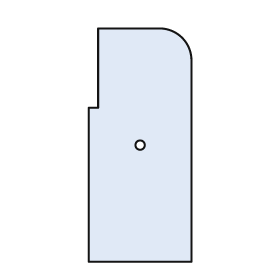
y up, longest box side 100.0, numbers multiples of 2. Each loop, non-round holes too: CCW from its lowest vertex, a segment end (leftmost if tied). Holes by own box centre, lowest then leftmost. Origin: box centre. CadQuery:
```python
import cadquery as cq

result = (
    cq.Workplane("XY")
    .moveTo(-22.0, -50.0)
    .lineTo(22.0, -50.0)
    .lineTo(22.0, 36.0)
    .threePointArc((18.0, 46.0), (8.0, 50.0))
    .lineTo(-18.0, 50.0)
    .lineTo(-18.0, 16.0)
    .lineTo(-22.0, 16.0)
    .close()
    .moveTo(0.0, 0.0)
    .circle(2.0)
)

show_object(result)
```